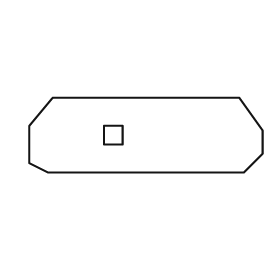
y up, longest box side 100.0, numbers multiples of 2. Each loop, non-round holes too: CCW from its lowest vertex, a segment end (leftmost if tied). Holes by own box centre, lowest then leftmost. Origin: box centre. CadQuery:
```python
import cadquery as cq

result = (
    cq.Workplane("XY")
    .moveTo(-42.0, -16.0)
    .lineTo(42.0, -16.0)
    .lineTo(50.0, -8.0)
    .lineTo(50.0, 2.0)
    .lineTo(40.0, 16.0)
    .lineTo(-40.0, 16.0)
    .lineTo(-50.0, 4.0)
    .lineTo(-50.0, -12.0)
    .close()
    .moveTo(-18.0, -4.0)
    .lineTo(-10.0, -4.0)
    .lineTo(-10.0, 4.0)
    .lineTo(-18.0, 4.0)
    .close()
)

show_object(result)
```